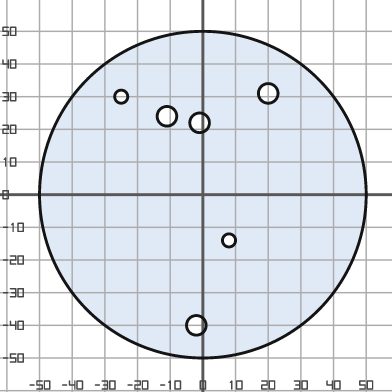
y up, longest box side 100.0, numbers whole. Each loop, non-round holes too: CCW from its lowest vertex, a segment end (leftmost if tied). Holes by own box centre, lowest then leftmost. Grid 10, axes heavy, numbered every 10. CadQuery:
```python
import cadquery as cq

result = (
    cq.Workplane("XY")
    .moveTo(0.0, 0.0)
    .circle(50.0)
    .moveTo(-2.0, -40.0)
    .circle(3.0)
    .moveTo(8.0, -14.0)
    .circle(2.0)
    .moveTo(-1.0, 22.0)
    .circle(3.0)
    .moveTo(-11.0, 24.0)
    .circle(3.0)
    .moveTo(-25.0, 30.0)
    .circle(2.0)
    .moveTo(20.0, 31.0)
    .circle(3.0)
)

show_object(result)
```